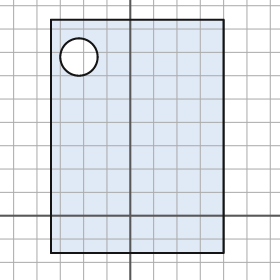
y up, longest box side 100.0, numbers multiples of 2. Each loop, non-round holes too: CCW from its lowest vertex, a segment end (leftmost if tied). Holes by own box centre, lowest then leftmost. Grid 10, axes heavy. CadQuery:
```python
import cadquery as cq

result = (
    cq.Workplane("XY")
    .moveTo(-34.0, -16.0)
    .lineTo(40.0, -16.0)
    .lineTo(40.0, 84.0)
    .lineTo(-34.0, 84.0)
    .close()
    .moveTo(-22.0, 68.0)
    .circle(8.0)
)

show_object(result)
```